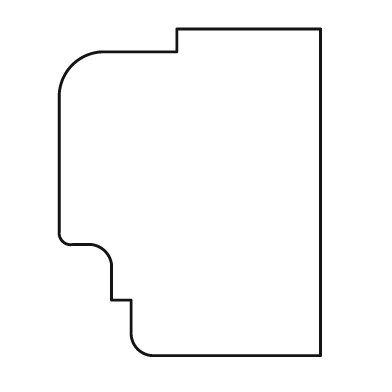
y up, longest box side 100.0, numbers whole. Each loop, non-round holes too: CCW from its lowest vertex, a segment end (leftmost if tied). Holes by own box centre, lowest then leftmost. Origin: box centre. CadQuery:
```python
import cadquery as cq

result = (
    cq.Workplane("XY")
    .moveTo(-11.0, -50.0)
    .lineTo(40.0, -50.0)
    .lineTo(40.0, 50.0)
    .lineTo(-4.0, 50.0)
    .lineTo(-4.0, 43.0)
    .lineTo(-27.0, 43.0)
    .threePointArc((-36.0, 39.0), (-40.0, 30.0))
    .lineTo(-40.0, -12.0)
    .threePointArc((-39.0, -15.0), (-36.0, -16.0))
    .lineTo(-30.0, -16.0)
    .threePointArc((-26.0, -18.0), (-24.0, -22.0))
    .lineTo(-24.0, -33.0)
    .lineTo(-18.0, -33.0)
    .lineTo(-18.0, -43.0)
    .threePointArc((-16.0, -48.0), (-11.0, -50.0))
    .close()
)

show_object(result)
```